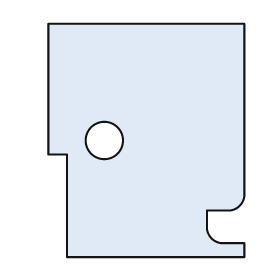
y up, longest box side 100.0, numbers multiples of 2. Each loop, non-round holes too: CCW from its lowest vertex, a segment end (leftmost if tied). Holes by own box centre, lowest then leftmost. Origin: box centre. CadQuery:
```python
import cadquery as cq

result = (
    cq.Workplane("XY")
    .moveTo(-34.0, -50.0)
    .lineTo(42.0, -50.0)
    .lineTo(42.0, -44.0)
    .lineTo(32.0, -44.0)
    .threePointArc((28.0, -42.0), (26.0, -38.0))
    .lineTo(26.0, -30.0)
    .lineTo(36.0, -30.0)
    .threePointArc((40.0, -28.0), (42.0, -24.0))
    .lineTo(42.0, 50.0)
    .lineTo(-42.0, 50.0)
    .lineTo(-42.0, -6.0)
    .lineTo(-34.0, -6.0)
    .close()
    .moveTo(-18.0, 0.0)
    .circle(8.0)
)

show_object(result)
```